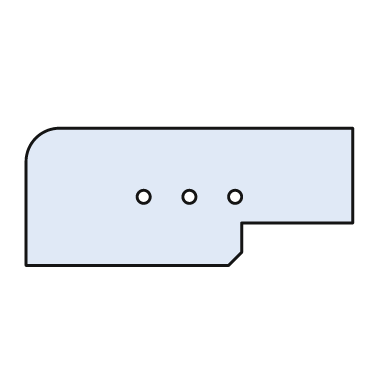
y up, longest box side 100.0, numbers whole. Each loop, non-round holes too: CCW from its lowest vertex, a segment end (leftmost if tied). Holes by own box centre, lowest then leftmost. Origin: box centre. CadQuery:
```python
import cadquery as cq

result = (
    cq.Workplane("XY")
    .moveTo(-50.0, -21.0)
    .lineTo(12.0, -21.0)
    .lineTo(16.0, -17.0)
    .lineTo(16.0, -8.0)
    .lineTo(50.0, -8.0)
    .lineTo(50.0, 21.0)
    .lineTo(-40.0, 21.0)
    .threePointArc((-47.0, 18.0), (-50.0, 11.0))
    .close()
    .moveTo(-14.0, 0.0)
    .circle(2.0)
    .moveTo(0.0, 0.0)
    .circle(2.0)
    .moveTo(14.0, 0.0)
    .circle(2.0)
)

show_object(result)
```